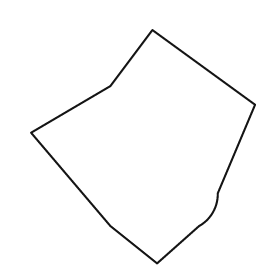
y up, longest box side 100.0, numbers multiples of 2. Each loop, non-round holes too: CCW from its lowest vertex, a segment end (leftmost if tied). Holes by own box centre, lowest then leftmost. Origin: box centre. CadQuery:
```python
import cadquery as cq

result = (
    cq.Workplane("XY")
    .moveTo(6.0, -50.0)
    .lineTo(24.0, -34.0)
    .threePointArc((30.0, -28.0), (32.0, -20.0))
    .lineTo(48.0, 18.0)
    .lineTo(4.0, 50.0)
    .lineTo(-14.0, 26.0)
    .lineTo(-48.0, 6.0)
    .lineTo(-14.0, -34.0)
    .close()
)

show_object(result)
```